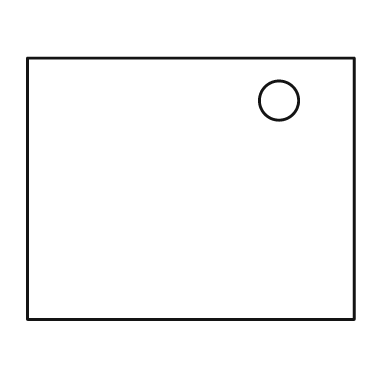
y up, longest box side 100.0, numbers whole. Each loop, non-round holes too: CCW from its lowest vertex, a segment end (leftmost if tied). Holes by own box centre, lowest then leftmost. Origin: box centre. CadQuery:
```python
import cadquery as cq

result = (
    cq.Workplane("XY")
    .moveTo(-50.0, -40.0)
    .lineTo(50.0, -40.0)
    .lineTo(50.0, 40.0)
    .lineTo(-50.0, 40.0)
    .close()
    .moveTo(27.0, 27.0)
    .circle(6.0)
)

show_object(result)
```